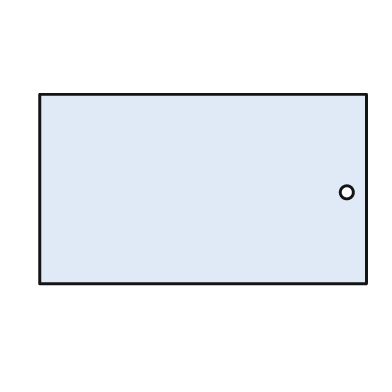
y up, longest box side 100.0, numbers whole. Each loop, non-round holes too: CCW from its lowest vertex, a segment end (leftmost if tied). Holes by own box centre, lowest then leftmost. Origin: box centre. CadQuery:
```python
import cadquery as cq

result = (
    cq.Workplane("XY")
    .moveTo(-50.0, -29.0)
    .lineTo(50.0, -29.0)
    .lineTo(50.0, 29.0)
    .lineTo(-50.0, 29.0)
    .close()
    .moveTo(44.0, -1.0)
    .circle(2.0)
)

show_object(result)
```